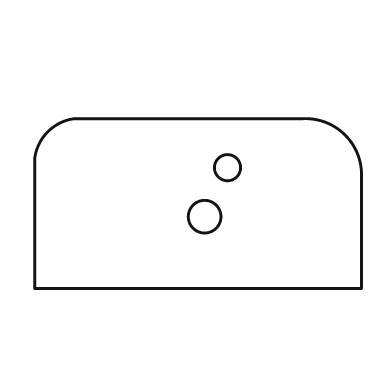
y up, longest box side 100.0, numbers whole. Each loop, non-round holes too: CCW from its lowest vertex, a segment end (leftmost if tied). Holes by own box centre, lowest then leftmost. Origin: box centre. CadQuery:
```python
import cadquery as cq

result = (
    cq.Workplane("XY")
    .moveTo(-50.0, -26.0)
    .lineTo(50.0, -26.0)
    .lineTo(50.0, 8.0)
    .threePointArc((45.0, 21.0), (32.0, 26.0))
    .lineTo(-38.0, 26.0)
    .threePointArc((-46.0, 22.0), (-50.0, 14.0))
    .close()
    .moveTo(2.0, -4.0)
    .circle(5.0)
    .moveTo(9.0, 11.0)
    .circle(4.0)
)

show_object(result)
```